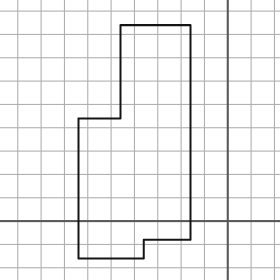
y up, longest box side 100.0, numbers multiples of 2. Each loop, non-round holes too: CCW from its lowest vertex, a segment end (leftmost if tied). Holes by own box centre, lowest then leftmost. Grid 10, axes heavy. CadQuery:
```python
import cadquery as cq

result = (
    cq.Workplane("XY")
    .moveTo(-64.0, -16.0)
    .lineTo(-36.0, -16.0)
    .lineTo(-36.0, -8.0)
    .lineTo(-16.0, -8.0)
    .lineTo(-16.0, 84.0)
    .lineTo(-46.0, 84.0)
    .lineTo(-46.0, 44.0)
    .lineTo(-64.0, 44.0)
    .close()
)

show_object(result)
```